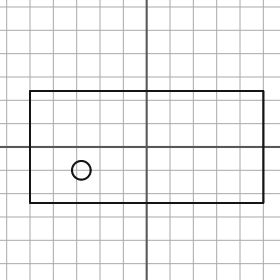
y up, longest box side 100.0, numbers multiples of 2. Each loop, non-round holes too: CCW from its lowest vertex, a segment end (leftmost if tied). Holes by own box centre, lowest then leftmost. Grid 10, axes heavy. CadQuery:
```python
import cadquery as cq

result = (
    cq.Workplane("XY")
    .moveTo(-50.0, -24.0)
    .lineTo(50.0, -24.0)
    .lineTo(50.0, 24.0)
    .lineTo(-50.0, 24.0)
    .close()
    .moveTo(-28.0, -10.0)
    .circle(4.0)
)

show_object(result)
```